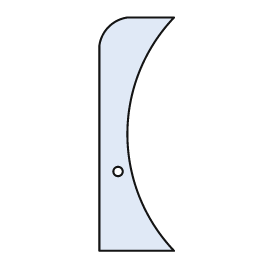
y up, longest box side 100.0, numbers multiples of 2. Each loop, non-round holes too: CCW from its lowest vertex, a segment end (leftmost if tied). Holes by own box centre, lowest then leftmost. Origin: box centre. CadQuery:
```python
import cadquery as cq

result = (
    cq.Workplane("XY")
    .moveTo(-16.0, -50.0)
    .lineTo(16.0, -50.0)
    .threePointArc((-4.0, 0.0), (16.0, 50.0))
    .lineTo(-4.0, 50.0)
    .threePointArc((-12.0, 46.0), (-16.0, 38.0))
    .close()
    .moveTo(-8.0, -16.0)
    .circle(2.0)
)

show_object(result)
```